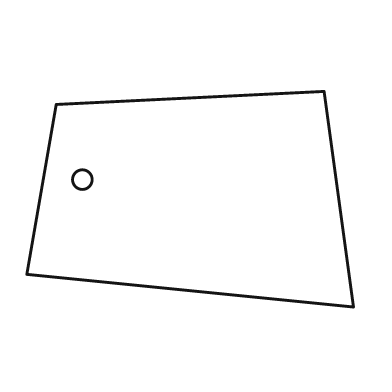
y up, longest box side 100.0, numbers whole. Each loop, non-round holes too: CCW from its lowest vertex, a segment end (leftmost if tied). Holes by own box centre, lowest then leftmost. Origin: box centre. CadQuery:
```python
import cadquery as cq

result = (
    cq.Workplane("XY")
    .moveTo(50.0, -33.0)
    .lineTo(41.0, 33.0)
    .lineTo(-41.0, 29.0)
    .lineTo(-50.0, -23.0)
    .close()
    .moveTo(-33.0, 6.0)
    .circle(3.0)
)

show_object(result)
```